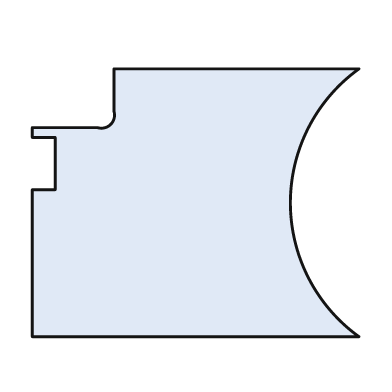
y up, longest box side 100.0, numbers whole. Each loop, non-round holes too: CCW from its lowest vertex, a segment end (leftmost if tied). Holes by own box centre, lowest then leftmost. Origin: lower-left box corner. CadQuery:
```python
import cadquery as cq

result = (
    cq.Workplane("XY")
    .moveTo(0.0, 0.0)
    .lineTo(100.0, 0.0)
    .threePointArc((79.0, 41.0), (100.0, 82.0))
    .lineTo(25.0, 82.0)
    .lineTo(25.0, 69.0)
    .threePointArc((24.0, 65.0), (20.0, 64.0))
    .lineTo(0.0, 64.0)
    .lineTo(0.0, 61.0)
    .lineTo(7.0, 61.0)
    .lineTo(7.0, 45.0)
    .lineTo(0.0, 45.0)
    .close()
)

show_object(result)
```